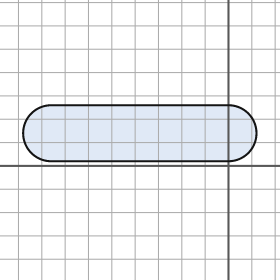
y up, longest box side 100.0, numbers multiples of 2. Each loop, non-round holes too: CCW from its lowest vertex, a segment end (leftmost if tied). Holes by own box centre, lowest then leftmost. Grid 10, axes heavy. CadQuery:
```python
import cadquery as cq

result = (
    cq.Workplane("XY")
    .moveTo(-76.0, 2.0)
    .lineTo(0.0, 2.0)
    .threePointArc((12.0, 14.0), (0.0, 26.0))
    .lineTo(-76.0, 26.0)
    .threePointArc((-88.0, 14.0), (-76.0, 2.0))
    .close()
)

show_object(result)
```